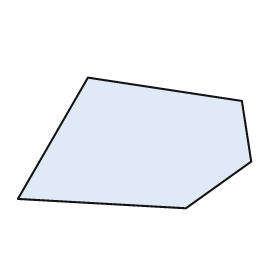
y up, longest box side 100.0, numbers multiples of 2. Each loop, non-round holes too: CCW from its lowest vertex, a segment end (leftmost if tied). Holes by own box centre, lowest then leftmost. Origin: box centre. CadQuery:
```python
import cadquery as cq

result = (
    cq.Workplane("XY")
    .moveTo(22.0, -28.0)
    .lineTo(50.0, -8.0)
    .lineTo(46.0, 18.0)
    .lineTo(-20.0, 28.0)
    .lineTo(-50.0, -24.0)
    .close()
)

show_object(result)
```